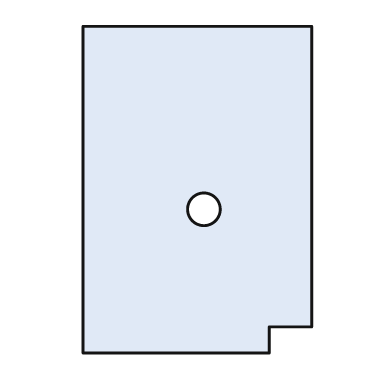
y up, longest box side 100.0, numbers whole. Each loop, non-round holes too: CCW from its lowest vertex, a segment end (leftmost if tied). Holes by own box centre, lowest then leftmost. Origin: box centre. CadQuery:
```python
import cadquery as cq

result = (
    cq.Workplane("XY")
    .moveTo(-35.0, -50.0)
    .lineTo(22.0, -50.0)
    .lineTo(22.0, -42.0)
    .lineTo(35.0, -42.0)
    .lineTo(35.0, 50.0)
    .lineTo(-35.0, 50.0)
    .close()
    .moveTo(2.0, -6.0)
    .circle(5.0)
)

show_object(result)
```